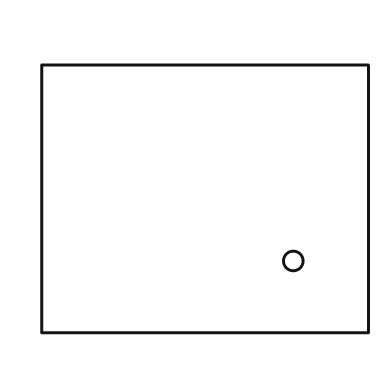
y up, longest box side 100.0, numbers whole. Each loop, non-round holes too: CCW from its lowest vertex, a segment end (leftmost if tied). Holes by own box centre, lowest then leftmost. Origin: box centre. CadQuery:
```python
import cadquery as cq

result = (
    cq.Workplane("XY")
    .moveTo(-50.0, -41.0)
    .lineTo(50.0, -41.0)
    .lineTo(50.0, 41.0)
    .lineTo(-50.0, 41.0)
    .close()
    .moveTo(27.0, -19.0)
    .circle(3.0)
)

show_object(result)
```